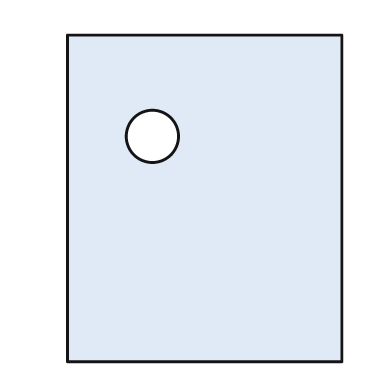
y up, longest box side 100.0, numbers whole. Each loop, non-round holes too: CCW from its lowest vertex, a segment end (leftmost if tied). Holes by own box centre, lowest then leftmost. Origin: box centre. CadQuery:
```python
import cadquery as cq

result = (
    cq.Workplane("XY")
    .moveTo(-42.0, -50.0)
    .lineTo(42.0, -50.0)
    .lineTo(42.0, 50.0)
    .lineTo(-42.0, 50.0)
    .close()
    .moveTo(-16.0, 19.0)
    .circle(8.0)
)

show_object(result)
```